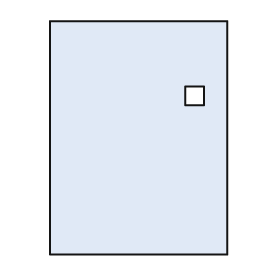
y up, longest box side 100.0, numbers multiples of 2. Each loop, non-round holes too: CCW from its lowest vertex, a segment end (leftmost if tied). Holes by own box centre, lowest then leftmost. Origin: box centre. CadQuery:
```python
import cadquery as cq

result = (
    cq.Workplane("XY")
    .moveTo(-38.0, -50.0)
    .lineTo(38.0, -50.0)
    .lineTo(38.0, 50.0)
    .lineTo(-38.0, 50.0)
    .close()
    .moveTo(20.0, 14.0)
    .lineTo(28.0, 14.0)
    .lineTo(28.0, 22.0)
    .lineTo(20.0, 22.0)
    .close()
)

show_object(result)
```